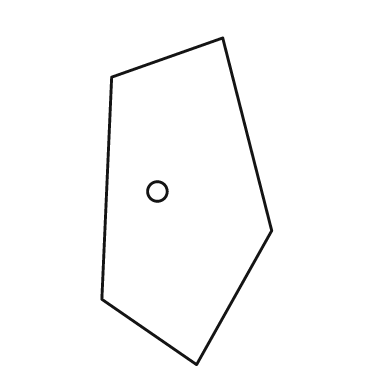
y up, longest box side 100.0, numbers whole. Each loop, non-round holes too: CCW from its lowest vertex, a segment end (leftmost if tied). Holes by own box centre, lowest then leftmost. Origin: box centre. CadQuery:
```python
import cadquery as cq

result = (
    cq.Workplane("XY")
    .moveTo(3.0, -50.0)
    .lineTo(26.0, -9.0)
    .lineTo(11.0, 50.0)
    .lineTo(-23.0, 38.0)
    .lineTo(-26.0, -30.0)
    .close()
    .moveTo(-9.0, 3.0)
    .circle(3.0)
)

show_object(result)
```